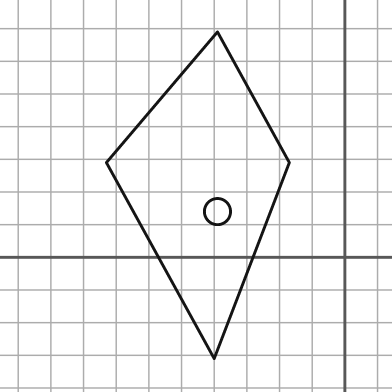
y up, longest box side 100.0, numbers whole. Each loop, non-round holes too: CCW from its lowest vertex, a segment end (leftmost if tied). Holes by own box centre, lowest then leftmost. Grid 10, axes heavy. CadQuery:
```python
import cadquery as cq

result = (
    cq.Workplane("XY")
    .moveTo(-40.0, -31.0)
    .lineTo(-17.0, 29.0)
    .lineTo(-39.0, 69.0)
    .lineTo(-73.0, 29.0)
    .close()
    .moveTo(-39.0, 14.0)
    .circle(4.0)
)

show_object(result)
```